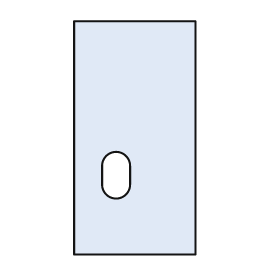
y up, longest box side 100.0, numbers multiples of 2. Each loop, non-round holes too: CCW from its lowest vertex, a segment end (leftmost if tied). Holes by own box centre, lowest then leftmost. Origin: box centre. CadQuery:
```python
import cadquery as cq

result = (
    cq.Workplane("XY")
    .moveTo(-26.0, -50.0)
    .lineTo(26.0, -50.0)
    .lineTo(26.0, 50.0)
    .lineTo(-26.0, 50.0)
    .close()
    .moveTo(-14.0, -20.0)
    .threePointArc((-8.0, -26.0), (-2.0, -20.0))
    .lineTo(-2.0, -12.0)
    .threePointArc((-8.0, -6.0), (-14.0, -12.0))
    .close()
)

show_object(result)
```